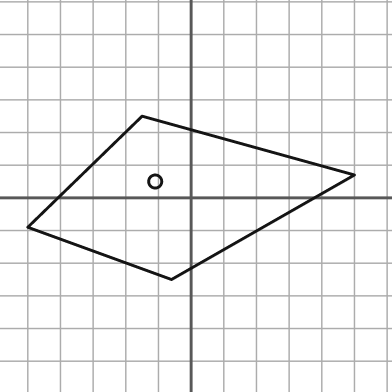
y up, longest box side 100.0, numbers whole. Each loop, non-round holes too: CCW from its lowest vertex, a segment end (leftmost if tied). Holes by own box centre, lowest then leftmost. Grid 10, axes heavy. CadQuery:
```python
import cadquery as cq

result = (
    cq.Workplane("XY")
    .moveTo(-6.0, -25.0)
    .lineTo(50.0, 7.0)
    .lineTo(-15.0, 25.0)
    .lineTo(-50.0, -9.0)
    .close()
    .moveTo(-11.0, 5.0)
    .circle(2.0)
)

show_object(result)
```